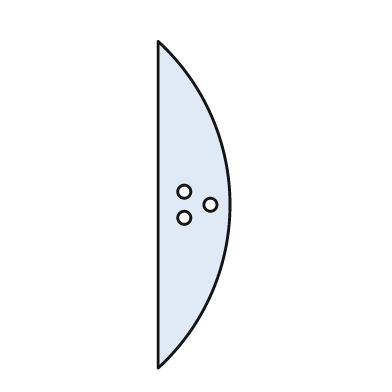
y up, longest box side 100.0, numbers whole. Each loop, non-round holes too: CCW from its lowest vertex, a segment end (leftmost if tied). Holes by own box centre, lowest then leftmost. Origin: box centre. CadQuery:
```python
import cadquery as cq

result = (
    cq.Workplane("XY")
    .moveTo(-11.0, -50.0)
    .threePointArc((11.0, 0.0), (-11.0, 50.0))
    .close()
    .moveTo(-3.0, -4.0)
    .circle(2.0)
    .moveTo(5.0, 0.0)
    .circle(2.0)
    .moveTo(-3.0, 4.0)
    .circle(2.0)
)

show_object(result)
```